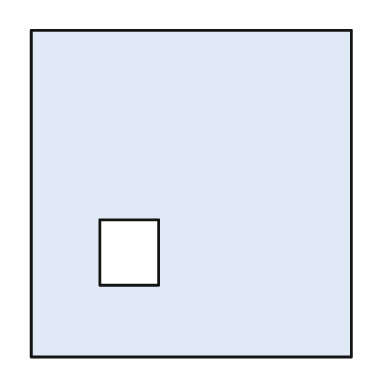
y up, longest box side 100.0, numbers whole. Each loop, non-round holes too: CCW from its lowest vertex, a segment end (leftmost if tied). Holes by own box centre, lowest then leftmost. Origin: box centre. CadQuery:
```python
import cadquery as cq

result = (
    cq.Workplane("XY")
    .moveTo(-49.0, -50.0)
    .lineTo(49.0, -50.0)
    .lineTo(49.0, 50.0)
    .lineTo(-49.0, 50.0)
    .close()
    .moveTo(-28.0, -28.0)
    .lineTo(-10.0, -28.0)
    .lineTo(-10.0, -8.0)
    .lineTo(-28.0, -8.0)
    .close()
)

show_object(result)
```